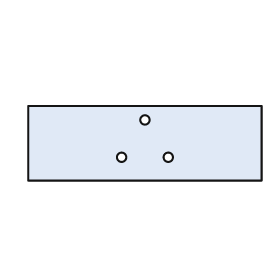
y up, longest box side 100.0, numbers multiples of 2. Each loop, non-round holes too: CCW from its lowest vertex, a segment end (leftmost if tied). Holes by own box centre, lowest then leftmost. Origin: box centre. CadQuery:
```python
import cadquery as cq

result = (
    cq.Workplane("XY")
    .moveTo(-50.0, -16.0)
    .lineTo(50.0, -16.0)
    .lineTo(50.0, 16.0)
    .lineTo(-50.0, 16.0)
    .close()
    .moveTo(-10.0, -6.0)
    .circle(2.0)
    .moveTo(10.0, -6.0)
    .circle(2.0)
    .moveTo(0.0, 10.0)
    .circle(2.0)
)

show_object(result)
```